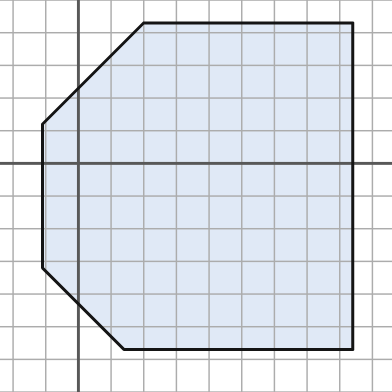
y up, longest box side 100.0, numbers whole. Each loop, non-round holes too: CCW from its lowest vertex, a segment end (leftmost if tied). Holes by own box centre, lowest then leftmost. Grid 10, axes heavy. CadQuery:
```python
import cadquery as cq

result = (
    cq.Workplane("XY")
    .moveTo(14.0, -57.0)
    .lineTo(84.0, -57.0)
    .lineTo(84.0, 43.0)
    .lineTo(20.0, 43.0)
    .lineTo(-11.0, 12.0)
    .lineTo(-11.0, -32.0)
    .close()
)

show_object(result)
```